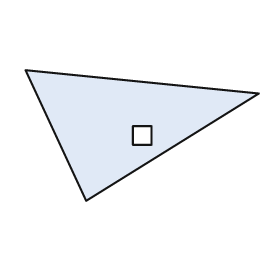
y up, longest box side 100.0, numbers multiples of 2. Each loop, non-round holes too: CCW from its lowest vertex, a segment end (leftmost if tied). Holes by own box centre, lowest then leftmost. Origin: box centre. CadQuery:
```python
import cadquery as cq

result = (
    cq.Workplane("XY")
    .moveTo(-24.0, -28.0)
    .lineTo(50.0, 18.0)
    .lineTo(-50.0, 28.0)
    .close()
    .moveTo(-4.0, -4.0)
    .lineTo(4.0, -4.0)
    .lineTo(4.0, 4.0)
    .lineTo(-4.0, 4.0)
    .close()
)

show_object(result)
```